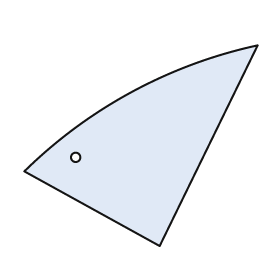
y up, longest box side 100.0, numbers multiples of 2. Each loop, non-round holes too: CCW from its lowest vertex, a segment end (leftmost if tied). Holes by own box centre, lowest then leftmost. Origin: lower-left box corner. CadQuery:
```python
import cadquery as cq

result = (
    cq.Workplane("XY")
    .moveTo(58.0, 0.0)
    .lineTo(100.0, 86.0)
    .threePointArc((46.0, 66.0), (0.0, 32.0))
    .close()
    .moveTo(22.0, 38.0)
    .circle(2.0)
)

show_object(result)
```